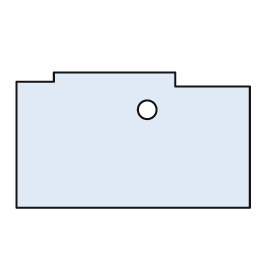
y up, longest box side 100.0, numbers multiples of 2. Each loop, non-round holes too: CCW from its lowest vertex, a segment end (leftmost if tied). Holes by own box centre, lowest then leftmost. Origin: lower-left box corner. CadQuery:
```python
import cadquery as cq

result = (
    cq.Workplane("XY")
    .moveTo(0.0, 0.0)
    .lineTo(100.0, 0.0)
    .lineTo(100.0, 52.0)
    .lineTo(68.0, 52.0)
    .lineTo(68.0, 58.0)
    .lineTo(16.0, 58.0)
    .lineTo(16.0, 54.0)
    .lineTo(0.0, 54.0)
    .close()
    .moveTo(56.0, 42.0)
    .circle(4.0)
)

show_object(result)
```